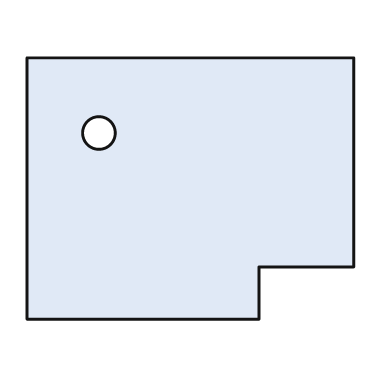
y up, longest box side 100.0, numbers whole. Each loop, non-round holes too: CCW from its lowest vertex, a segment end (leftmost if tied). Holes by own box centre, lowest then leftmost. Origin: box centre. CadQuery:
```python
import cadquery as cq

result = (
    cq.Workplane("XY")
    .moveTo(-50.0, -40.0)
    .lineTo(21.0, -40.0)
    .lineTo(21.0, -24.0)
    .lineTo(50.0, -24.0)
    .lineTo(50.0, 40.0)
    .lineTo(-50.0, 40.0)
    .close()
    .moveTo(-28.0, 17.0)
    .circle(5.0)
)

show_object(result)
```